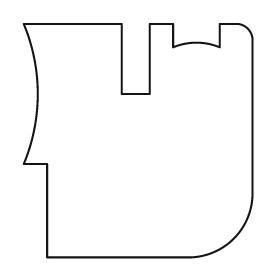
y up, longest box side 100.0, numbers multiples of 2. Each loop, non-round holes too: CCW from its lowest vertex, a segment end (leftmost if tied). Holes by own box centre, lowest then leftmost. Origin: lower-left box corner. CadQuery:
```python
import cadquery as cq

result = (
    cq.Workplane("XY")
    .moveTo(10.0, 0.0)
    .lineTo(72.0, 0.0)
    .threePointArc((90.0, 8.0), (98.0, 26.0))
    .lineTo(98.0, 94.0)
    .threePointArc((96.0, 98.0), (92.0, 100.0))
    .lineTo(84.0, 100.0)
    .lineTo(84.0, 90.0)
    .threePointArc((74.0, 92.0), (64.0, 90.0))
    .lineTo(64.0, 100.0)
    .lineTo(54.0, 100.0)
    .lineTo(54.0, 70.0)
    .lineTo(42.0, 70.0)
    .lineTo(42.0, 100.0)
    .lineTo(0.0, 100.0)
    .threePointArc((6.0, 70.0), (0.0, 40.0))
    .lineTo(10.0, 40.0)
    .close()
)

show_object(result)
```